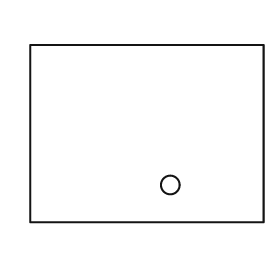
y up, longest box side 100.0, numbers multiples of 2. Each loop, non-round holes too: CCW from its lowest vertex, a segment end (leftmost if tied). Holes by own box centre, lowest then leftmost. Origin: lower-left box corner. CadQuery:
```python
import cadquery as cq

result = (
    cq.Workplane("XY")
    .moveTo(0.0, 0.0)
    .lineTo(100.0, 0.0)
    .lineTo(100.0, 76.0)
    .lineTo(0.0, 76.0)
    .close()
    .moveTo(60.0, 16.0)
    .circle(4.0)
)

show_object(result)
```